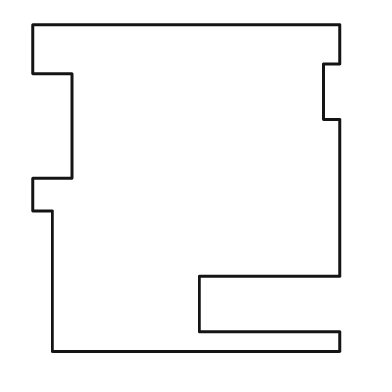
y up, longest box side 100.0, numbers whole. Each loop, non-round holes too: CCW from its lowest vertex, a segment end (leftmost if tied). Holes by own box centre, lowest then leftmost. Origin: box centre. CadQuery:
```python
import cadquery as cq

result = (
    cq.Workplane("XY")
    .moveTo(-41.0, -50.0)
    .lineTo(47.0, -50.0)
    .lineTo(47.0, -44.0)
    .lineTo(4.0, -44.0)
    .lineTo(4.0, -27.0)
    .lineTo(47.0, -27.0)
    .lineTo(47.0, 21.0)
    .lineTo(42.0, 21.0)
    .lineTo(42.0, 38.0)
    .lineTo(47.0, 38.0)
    .lineTo(47.0, 50.0)
    .lineTo(-47.0, 50.0)
    .lineTo(-47.0, 35.0)
    .lineTo(-35.0, 35.0)
    .lineTo(-35.0, 3.0)
    .lineTo(-47.0, 3.0)
    .lineTo(-47.0, -7.0)
    .lineTo(-41.0, -7.0)
    .close()
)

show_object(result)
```